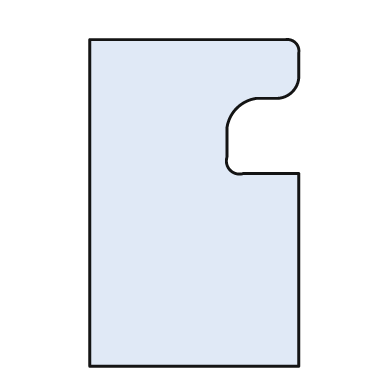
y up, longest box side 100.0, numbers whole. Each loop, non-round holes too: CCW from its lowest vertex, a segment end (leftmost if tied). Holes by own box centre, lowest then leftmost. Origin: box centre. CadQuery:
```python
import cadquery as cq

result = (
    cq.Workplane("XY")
    .moveTo(-32.0, -50.0)
    .lineTo(32.0, -50.0)
    .lineTo(32.0, 9.0)
    .lineTo(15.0, 9.0)
    .threePointArc((11.0, 10.0), (10.0, 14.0))
    .lineTo(10.0, 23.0)
    .threePointArc((13.0, 29.0), (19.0, 32.0))
    .lineTo(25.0, 32.0)
    .threePointArc((30.0, 34.0), (32.0, 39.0))
    .lineTo(32.0, 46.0)
    .threePointArc((31.0, 49.0), (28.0, 50.0))
    .lineTo(-32.0, 50.0)
    .close()
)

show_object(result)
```